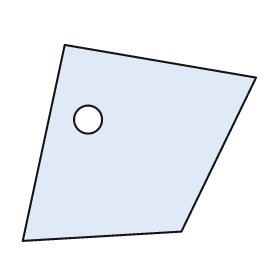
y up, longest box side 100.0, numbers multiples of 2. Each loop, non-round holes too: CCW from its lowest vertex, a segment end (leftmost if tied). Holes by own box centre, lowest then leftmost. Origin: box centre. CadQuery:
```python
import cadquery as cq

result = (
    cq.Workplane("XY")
    .moveTo(-50.0, -42.0)
    .lineTo(18.0, -38.0)
    .lineTo(50.0, 28.0)
    .lineTo(-32.0, 42.0)
    .close()
    .moveTo(-22.0, 10.0)
    .circle(6.0)
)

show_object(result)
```